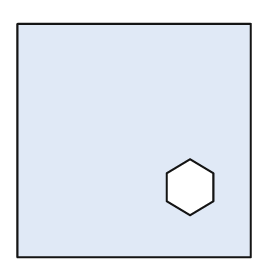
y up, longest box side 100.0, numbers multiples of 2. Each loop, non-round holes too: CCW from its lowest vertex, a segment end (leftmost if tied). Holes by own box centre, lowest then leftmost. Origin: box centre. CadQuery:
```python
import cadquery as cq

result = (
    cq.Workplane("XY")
    .moveTo(-50.0, -50.0)
    .lineTo(50.0, -50.0)
    .lineTo(50.0, 50.0)
    .lineTo(-50.0, 50.0)
    .close()
    .moveTo(24.0, -32.0)
    .lineTo(34.0, -26.0)
    .lineTo(34.0, -14.0)
    .lineTo(24.0, -8.0)
    .lineTo(14.0, -14.0)
    .lineTo(14.0, -26.0)
    .close()
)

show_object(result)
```